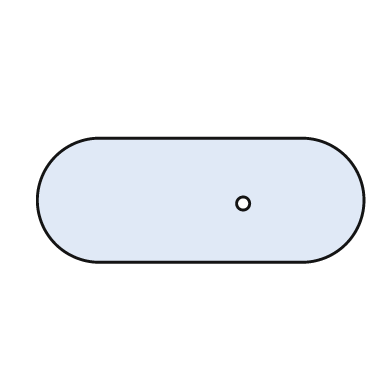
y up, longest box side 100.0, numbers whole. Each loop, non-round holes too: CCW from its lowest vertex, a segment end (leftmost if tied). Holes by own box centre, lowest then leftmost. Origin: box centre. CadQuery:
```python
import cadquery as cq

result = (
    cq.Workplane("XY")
    .moveTo(-31.0, -19.0)
    .lineTo(31.0, -19.0)
    .threePointArc((50.0, 0.0), (31.0, 19.0))
    .lineTo(-31.0, 19.0)
    .threePointArc((-50.0, 0.0), (-31.0, -19.0))
    .close()
    .moveTo(13.0, -1.0)
    .circle(2.0)
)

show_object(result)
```